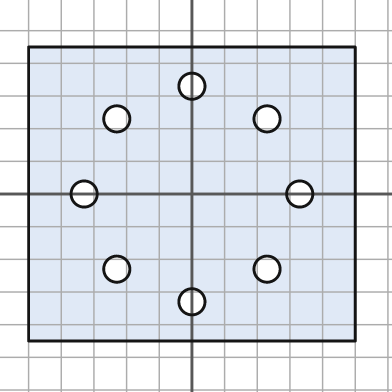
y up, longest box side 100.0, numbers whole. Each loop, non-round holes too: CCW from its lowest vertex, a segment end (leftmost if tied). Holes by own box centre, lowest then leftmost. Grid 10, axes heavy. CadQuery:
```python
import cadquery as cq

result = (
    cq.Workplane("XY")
    .moveTo(-50.0, -45.0)
    .lineTo(50.0, -45.0)
    .lineTo(50.0, 45.0)
    .lineTo(-50.0, 45.0)
    .close()
    .moveTo(0.0, -33.0)
    .circle(4.0)
    .moveTo(-23.0, -23.0)
    .circle(4.0)
    .moveTo(23.0, -23.0)
    .circle(4.0)
    .moveTo(-33.0, 0.0)
    .circle(4.0)
    .moveTo(33.0, 0.0)
    .circle(4.0)
    .moveTo(-23.0, 23.0)
    .circle(4.0)
    .moveTo(23.0, 23.0)
    .circle(4.0)
    .moveTo(0.0, 33.0)
    .circle(4.0)
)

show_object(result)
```